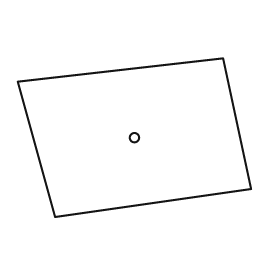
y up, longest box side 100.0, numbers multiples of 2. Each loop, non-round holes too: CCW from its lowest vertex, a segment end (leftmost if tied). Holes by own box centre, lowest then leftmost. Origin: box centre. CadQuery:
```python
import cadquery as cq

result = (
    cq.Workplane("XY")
    .moveTo(-34.0, -34.0)
    .lineTo(50.0, -22.0)
    .lineTo(38.0, 34.0)
    .lineTo(-50.0, 24.0)
    .close()
    .moveTo(0.0, 0.0)
    .circle(2.0)
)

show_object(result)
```